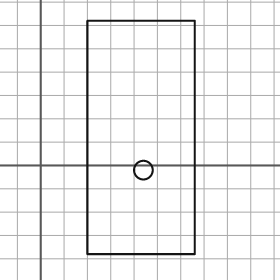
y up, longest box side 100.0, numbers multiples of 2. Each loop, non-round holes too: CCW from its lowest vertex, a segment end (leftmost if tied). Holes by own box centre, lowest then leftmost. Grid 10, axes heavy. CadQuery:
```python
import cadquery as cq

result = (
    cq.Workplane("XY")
    .moveTo(20.0, -38.0)
    .lineTo(66.0, -38.0)
    .lineTo(66.0, 62.0)
    .lineTo(20.0, 62.0)
    .close()
    .moveTo(44.0, -2.0)
    .circle(4.0)
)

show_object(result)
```